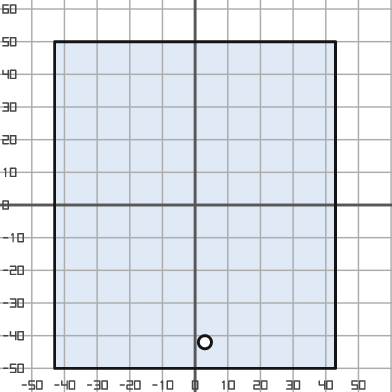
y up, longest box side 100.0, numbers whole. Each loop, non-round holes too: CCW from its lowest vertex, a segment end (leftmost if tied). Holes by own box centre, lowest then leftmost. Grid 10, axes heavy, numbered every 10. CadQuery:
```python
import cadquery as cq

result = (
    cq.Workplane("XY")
    .moveTo(-43.0, -50.0)
    .lineTo(43.0, -50.0)
    .lineTo(43.0, 50.0)
    .lineTo(-43.0, 50.0)
    .close()
    .moveTo(3.0, -42.0)
    .circle(2.0)
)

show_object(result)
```